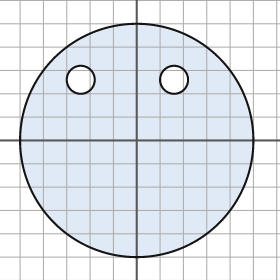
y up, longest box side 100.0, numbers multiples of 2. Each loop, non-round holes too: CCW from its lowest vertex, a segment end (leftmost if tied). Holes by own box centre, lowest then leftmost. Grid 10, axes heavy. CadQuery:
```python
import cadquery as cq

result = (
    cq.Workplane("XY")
    .moveTo(0.0, 0.0)
    .circle(50.0)
    .moveTo(-24.0, 26.0)
    .circle(6.0)
    .moveTo(16.0, 26.0)
    .circle(6.0)
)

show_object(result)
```